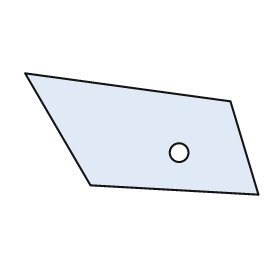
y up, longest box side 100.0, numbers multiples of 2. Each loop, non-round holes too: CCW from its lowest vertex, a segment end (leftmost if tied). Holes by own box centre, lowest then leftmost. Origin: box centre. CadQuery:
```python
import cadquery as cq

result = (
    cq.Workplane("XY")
    .moveTo(50.0, -26.0)
    .lineTo(38.0, 14.0)
    .lineTo(-50.0, 26.0)
    .lineTo(-22.0, -22.0)
    .close()
    .moveTo(16.0, -8.0)
    .circle(4.0)
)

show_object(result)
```